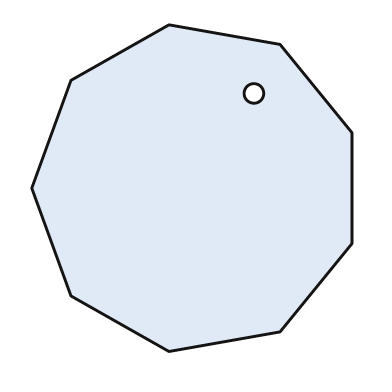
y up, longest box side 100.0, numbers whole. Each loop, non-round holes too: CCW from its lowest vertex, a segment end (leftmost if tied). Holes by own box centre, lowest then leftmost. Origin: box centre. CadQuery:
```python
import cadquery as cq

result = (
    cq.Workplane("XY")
    .moveTo(-7.0, -50.0)
    .lineTo(27.0, -44.0)
    .lineTo(49.0, -17.0)
    .lineTo(49.0, 17.0)
    .lineTo(27.0, 44.0)
    .lineTo(-7.0, 50.0)
    .lineTo(-37.0, 33.0)
    .lineTo(-49.0, 0.0)
    .lineTo(-37.0, -33.0)
    .close()
    .moveTo(19.0, 29.0)
    .circle(3.0)
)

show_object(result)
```